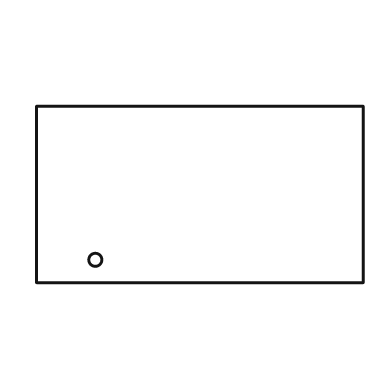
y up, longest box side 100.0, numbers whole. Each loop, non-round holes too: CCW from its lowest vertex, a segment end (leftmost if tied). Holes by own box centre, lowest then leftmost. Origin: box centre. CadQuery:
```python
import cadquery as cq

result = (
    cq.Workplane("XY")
    .moveTo(-50.0, -27.0)
    .lineTo(50.0, -27.0)
    .lineTo(50.0, 27.0)
    .lineTo(-50.0, 27.0)
    .close()
    .moveTo(-32.0, -20.0)
    .circle(2.0)
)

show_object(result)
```